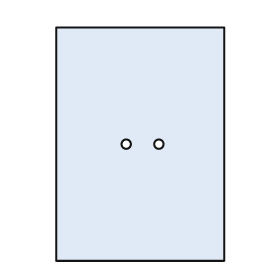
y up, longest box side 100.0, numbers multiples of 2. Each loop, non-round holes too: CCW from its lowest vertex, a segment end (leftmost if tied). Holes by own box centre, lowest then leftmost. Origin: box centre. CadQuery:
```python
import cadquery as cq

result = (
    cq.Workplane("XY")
    .moveTo(-36.0, -50.0)
    .lineTo(36.0, -50.0)
    .lineTo(36.0, 50.0)
    .lineTo(-36.0, 50.0)
    .close()
    .moveTo(-6.0, 0.0)
    .circle(2.0)
    .moveTo(8.0, 0.0)
    .circle(2.0)
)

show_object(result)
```